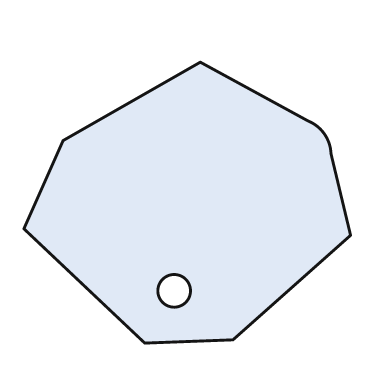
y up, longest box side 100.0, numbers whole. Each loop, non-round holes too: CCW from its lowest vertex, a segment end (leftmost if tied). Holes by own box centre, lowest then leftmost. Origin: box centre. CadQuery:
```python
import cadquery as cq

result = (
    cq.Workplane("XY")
    .moveTo(-13.0, -43.0)
    .lineTo(14.0, -42.0)
    .lineTo(50.0, -10.0)
    .lineTo(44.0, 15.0)
    .threePointArc((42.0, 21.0), (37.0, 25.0))
    .lineTo(4.0, 43.0)
    .lineTo(-38.0, 19.0)
    .lineTo(-50.0, -8.0)
    .close()
    .moveTo(-4.0, -27.0)
    .circle(5.0)
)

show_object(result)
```